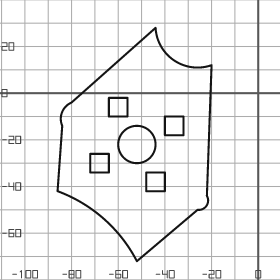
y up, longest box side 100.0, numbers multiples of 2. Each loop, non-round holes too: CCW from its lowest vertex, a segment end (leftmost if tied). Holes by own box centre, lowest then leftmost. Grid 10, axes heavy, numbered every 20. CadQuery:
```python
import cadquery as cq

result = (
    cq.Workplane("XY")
    .moveTo(-52.0, -72.0)
    .lineTo(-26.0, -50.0)
    .threePointArc((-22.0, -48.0), (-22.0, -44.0))
    .lineTo(-20.0, 12.0)
    .threePointArc((-36.0, 14.0), (-44.0, 28.0))
    .lineTo(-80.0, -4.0)
    .threePointArc((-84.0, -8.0), (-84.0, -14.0))
    .lineTo(-86.0, -42.0)
    .threePointArc((-66.0, -54.0), (-52.0, -72.0))
    .close()
    .moveTo(-48.0, -42.0)
    .lineTo(-40.0, -42.0)
    .lineTo(-40.0, -34.0)
    .lineTo(-48.0, -34.0)
    .close()
    .moveTo(-72.0, -34.0)
    .lineTo(-64.0, -34.0)
    .lineTo(-64.0, -26.0)
    .lineTo(-72.0, -26.0)
    .close()
    .moveTo(-52.0, -22.0)
    .circle(8.0)
    .moveTo(-40.0, -18.0)
    .lineTo(-32.0, -18.0)
    .lineTo(-32.0, -10.0)
    .lineTo(-40.0, -10.0)
    .close()
    .moveTo(-64.0, -10.0)
    .lineTo(-56.0, -10.0)
    .lineTo(-56.0, -2.0)
    .lineTo(-64.0, -2.0)
    .close()
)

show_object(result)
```